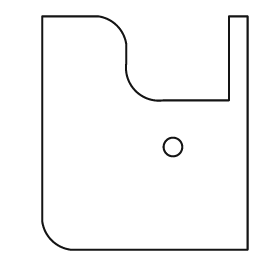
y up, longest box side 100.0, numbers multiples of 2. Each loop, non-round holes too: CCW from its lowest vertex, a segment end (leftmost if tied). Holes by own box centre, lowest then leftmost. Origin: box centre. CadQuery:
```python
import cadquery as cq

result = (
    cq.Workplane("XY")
    .moveTo(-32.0, -50.0)
    .lineTo(44.0, -50.0)
    .lineTo(44.0, 50.0)
    .lineTo(36.0, 50.0)
    .lineTo(36.0, 14.0)
    .lineTo(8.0, 14.0)
    .threePointArc((-4.0, 18.0), (-8.0, 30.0))
    .lineTo(-8.0, 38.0)
    .threePointArc((-12.0, 46.0), (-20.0, 50.0))
    .lineTo(-44.0, 50.0)
    .lineTo(-44.0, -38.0)
    .threePointArc((-40.0, -46.0), (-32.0, -50.0))
    .close()
    .moveTo(12.0, -6.0)
    .circle(4.0)
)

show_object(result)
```